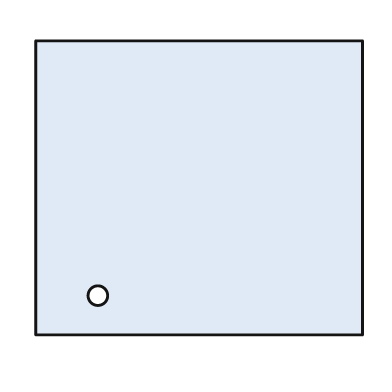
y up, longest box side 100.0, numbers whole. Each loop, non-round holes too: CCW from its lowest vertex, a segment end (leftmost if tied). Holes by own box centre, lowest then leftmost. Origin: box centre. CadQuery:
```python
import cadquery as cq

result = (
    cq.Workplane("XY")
    .moveTo(-50.0, -45.0)
    .lineTo(50.0, -45.0)
    .lineTo(50.0, 45.0)
    .lineTo(-50.0, 45.0)
    .close()
    .moveTo(-31.0, -33.0)
    .circle(3.0)
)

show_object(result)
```